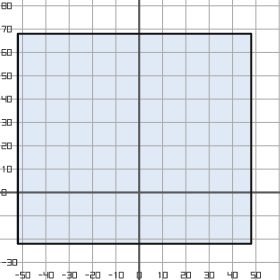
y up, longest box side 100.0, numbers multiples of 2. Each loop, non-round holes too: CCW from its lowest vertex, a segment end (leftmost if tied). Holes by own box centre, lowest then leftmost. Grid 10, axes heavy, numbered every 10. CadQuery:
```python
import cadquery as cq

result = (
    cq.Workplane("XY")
    .moveTo(-52.0, -22.0)
    .lineTo(48.0, -22.0)
    .lineTo(48.0, 68.0)
    .lineTo(-52.0, 68.0)
    .close()
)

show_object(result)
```